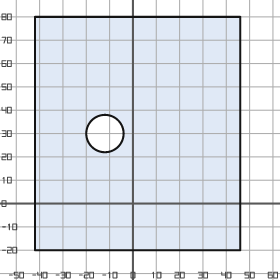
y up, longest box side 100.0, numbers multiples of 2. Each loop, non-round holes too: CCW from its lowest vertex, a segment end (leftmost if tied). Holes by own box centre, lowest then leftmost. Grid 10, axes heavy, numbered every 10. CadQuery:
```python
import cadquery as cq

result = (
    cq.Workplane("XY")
    .moveTo(-42.0, -20.0)
    .lineTo(46.0, -20.0)
    .lineTo(46.0, 80.0)
    .lineTo(-42.0, 80.0)
    .close()
    .moveTo(-12.0, 30.0)
    .circle(8.0)
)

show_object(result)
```